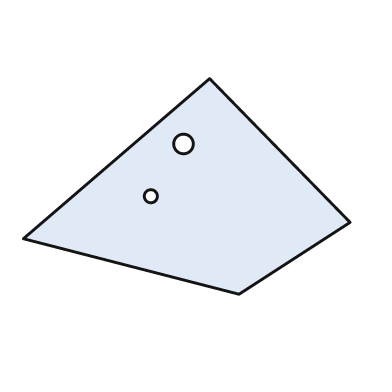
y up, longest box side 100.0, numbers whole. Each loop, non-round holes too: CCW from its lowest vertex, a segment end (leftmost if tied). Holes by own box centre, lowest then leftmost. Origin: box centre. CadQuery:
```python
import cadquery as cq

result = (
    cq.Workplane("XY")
    .moveTo(16.0, -33.0)
    .lineTo(50.0, -11.0)
    .lineTo(7.0, 33.0)
    .lineTo(-50.0, -16.0)
    .close()
    .moveTo(-11.0, -3.0)
    .circle(2.0)
    .moveTo(-1.0, 13.0)
    .circle(3.0)
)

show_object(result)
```